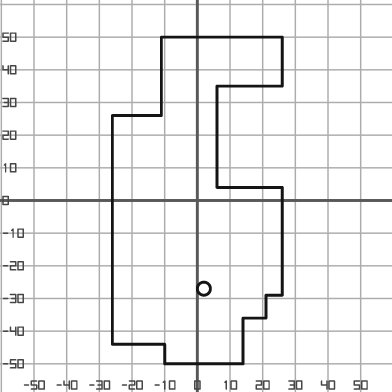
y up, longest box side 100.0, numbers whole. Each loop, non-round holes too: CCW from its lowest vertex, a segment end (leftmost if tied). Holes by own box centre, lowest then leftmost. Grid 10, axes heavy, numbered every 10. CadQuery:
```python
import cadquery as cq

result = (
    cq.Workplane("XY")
    .moveTo(-10.0, -50.0)
    .lineTo(14.0, -50.0)
    .lineTo(14.0, -36.0)
    .lineTo(21.0, -36.0)
    .lineTo(21.0, -29.0)
    .lineTo(26.0, -29.0)
    .lineTo(26.0, 4.0)
    .lineTo(6.0, 4.0)
    .lineTo(6.0, 35.0)
    .lineTo(26.0, 35.0)
    .lineTo(26.0, 50.0)
    .lineTo(-11.0, 50.0)
    .lineTo(-11.0, 26.0)
    .lineTo(-26.0, 26.0)
    .lineTo(-26.0, -44.0)
    .lineTo(-10.0, -44.0)
    .close()
    .moveTo(2.0, -27.0)
    .circle(2.0)
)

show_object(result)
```